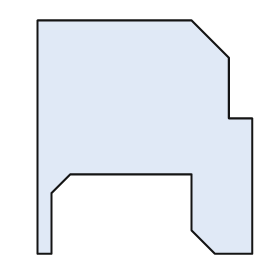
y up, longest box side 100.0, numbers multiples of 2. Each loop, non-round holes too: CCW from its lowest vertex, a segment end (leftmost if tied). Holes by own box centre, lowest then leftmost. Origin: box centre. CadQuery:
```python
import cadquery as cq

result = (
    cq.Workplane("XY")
    .moveTo(-46.0, -50.0)
    .lineTo(-40.0, -50.0)
    .lineTo(-40.0, -24.0)
    .lineTo(-32.0, -16.0)
    .lineTo(20.0, -16.0)
    .lineTo(20.0, -40.0)
    .lineTo(30.0, -50.0)
    .lineTo(46.0, -50.0)
    .lineTo(46.0, 8.0)
    .lineTo(36.0, 8.0)
    .lineTo(36.0, 34.0)
    .lineTo(20.0, 50.0)
    .lineTo(-46.0, 50.0)
    .close()
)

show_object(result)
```